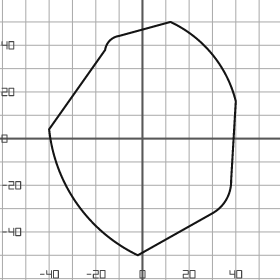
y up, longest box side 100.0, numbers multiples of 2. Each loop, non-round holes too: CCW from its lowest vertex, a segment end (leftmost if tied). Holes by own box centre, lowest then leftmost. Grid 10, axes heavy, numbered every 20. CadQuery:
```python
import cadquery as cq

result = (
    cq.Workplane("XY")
    .moveTo(-2.0, -50.0)
    .lineTo(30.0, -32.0)
    .threePointArc((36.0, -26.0), (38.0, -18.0))
    .lineTo(40.0, 16.0)
    .threePointArc((30.0, 36.0), (12.0, 50.0))
    .lineTo(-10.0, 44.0)
    .threePointArc((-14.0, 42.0), (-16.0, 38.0))
    .lineTo(-40.0, 4.0)
    .threePointArc((-28.0, -28.0), (-2.0, -50.0))
    .close()
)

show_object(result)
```